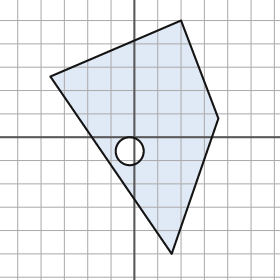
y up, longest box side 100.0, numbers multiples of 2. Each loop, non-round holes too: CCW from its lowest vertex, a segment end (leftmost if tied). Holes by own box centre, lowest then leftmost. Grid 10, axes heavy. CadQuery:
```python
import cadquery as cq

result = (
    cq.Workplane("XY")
    .moveTo(16.0, -50.0)
    .lineTo(36.0, 8.0)
    .lineTo(20.0, 50.0)
    .lineTo(-36.0, 26.0)
    .close()
    .moveTo(-2.0, -6.0)
    .circle(6.0)
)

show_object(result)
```